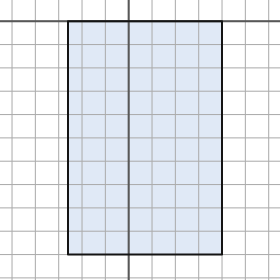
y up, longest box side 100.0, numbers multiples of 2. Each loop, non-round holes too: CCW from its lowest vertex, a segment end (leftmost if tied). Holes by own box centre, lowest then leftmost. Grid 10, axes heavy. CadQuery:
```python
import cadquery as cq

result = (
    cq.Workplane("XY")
    .moveTo(-26.0, -100.0)
    .lineTo(40.0, -100.0)
    .lineTo(40.0, 0.0)
    .lineTo(-26.0, 0.0)
    .close()
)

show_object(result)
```